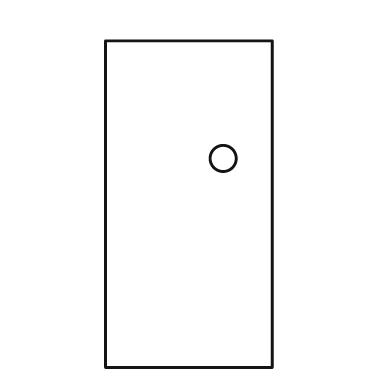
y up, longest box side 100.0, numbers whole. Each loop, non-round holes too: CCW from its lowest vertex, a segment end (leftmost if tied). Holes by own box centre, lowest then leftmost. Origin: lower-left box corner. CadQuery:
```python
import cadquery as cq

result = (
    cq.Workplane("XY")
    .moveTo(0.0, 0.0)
    .lineTo(51.0, 0.0)
    .lineTo(51.0, 100.0)
    .lineTo(0.0, 100.0)
    .close()
    .moveTo(36.0, 64.0)
    .circle(4.0)
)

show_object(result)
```